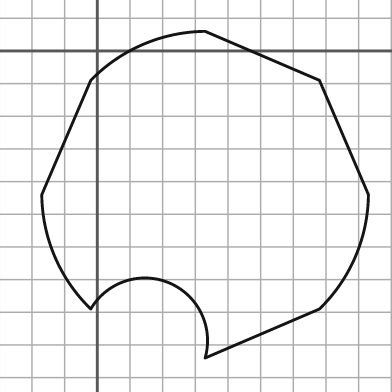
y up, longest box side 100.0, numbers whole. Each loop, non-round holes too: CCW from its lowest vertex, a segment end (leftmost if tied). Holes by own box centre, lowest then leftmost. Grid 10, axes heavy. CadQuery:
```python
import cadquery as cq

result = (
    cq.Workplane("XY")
    .moveTo(33.0, -94.0)
    .lineTo(68.0, -79.0)
    .threePointArc((79.0, -63.0), (83.0, -44.0))
    .lineTo(68.0, -9.0)
    .lineTo(33.0, 6.0)
    .threePointArc((14.0, 2.0), (-2.0, -9.0))
    .lineTo(-17.0, -44.0)
    .threePointArc((-13.0, -63.0), (-2.0, -79.0))
    .threePointArc((22.0, -71.0), (33.0, -94.0))
    .close()
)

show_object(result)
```